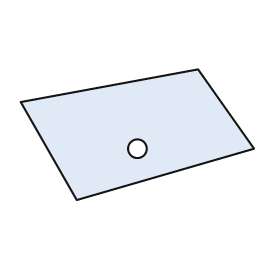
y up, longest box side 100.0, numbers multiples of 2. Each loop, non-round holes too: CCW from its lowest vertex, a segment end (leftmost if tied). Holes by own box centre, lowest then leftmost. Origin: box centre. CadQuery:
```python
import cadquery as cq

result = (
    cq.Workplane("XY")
    .moveTo(-26.0, -28.0)
    .lineTo(50.0, -6.0)
    .lineTo(26.0, 28.0)
    .lineTo(-50.0, 14.0)
    .close()
    .moveTo(0.0, -6.0)
    .circle(4.0)
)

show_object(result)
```